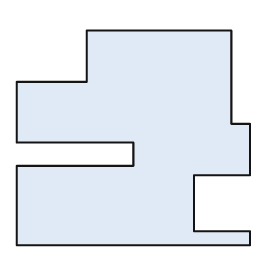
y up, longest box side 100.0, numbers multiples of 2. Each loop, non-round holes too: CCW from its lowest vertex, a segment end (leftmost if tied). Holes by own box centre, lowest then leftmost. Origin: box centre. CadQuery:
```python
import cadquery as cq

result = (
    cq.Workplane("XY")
    .moveTo(-50.0, -46.0)
    .lineTo(50.0, -46.0)
    .lineTo(50.0, -40.0)
    .lineTo(26.0, -40.0)
    .lineTo(26.0, -16.0)
    .lineTo(50.0, -16.0)
    .lineTo(50.0, 6.0)
    .lineTo(42.0, 6.0)
    .lineTo(42.0, 46.0)
    .lineTo(-20.0, 46.0)
    .lineTo(-20.0, 24.0)
    .lineTo(-50.0, 24.0)
    .lineTo(-50.0, -2.0)
    .lineTo(0.0, -2.0)
    .lineTo(0.0, -12.0)
    .lineTo(-50.0, -12.0)
    .close()
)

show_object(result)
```